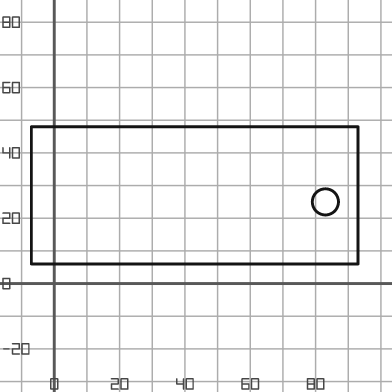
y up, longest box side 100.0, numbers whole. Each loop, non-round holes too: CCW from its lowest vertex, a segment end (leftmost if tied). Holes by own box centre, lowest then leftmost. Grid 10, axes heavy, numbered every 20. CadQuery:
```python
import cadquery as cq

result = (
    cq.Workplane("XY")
    .moveTo(-7.0, 6.0)
    .lineTo(93.0, 6.0)
    .lineTo(93.0, 48.0)
    .lineTo(-7.0, 48.0)
    .close()
    .moveTo(83.0, 25.0)
    .circle(4.0)
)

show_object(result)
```